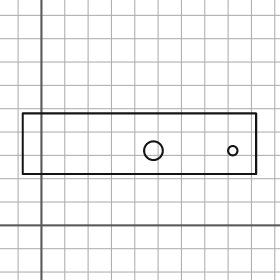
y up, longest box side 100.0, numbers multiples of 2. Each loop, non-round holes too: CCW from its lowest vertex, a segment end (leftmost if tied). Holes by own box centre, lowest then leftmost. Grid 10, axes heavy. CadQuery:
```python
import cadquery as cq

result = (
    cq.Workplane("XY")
    .moveTo(-8.0, 22.0)
    .lineTo(92.0, 22.0)
    .lineTo(92.0, 48.0)
    .lineTo(-8.0, 48.0)
    .close()
    .moveTo(48.0, 32.0)
    .circle(4.0)
    .moveTo(82.0, 32.0)
    .circle(2.0)
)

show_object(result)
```